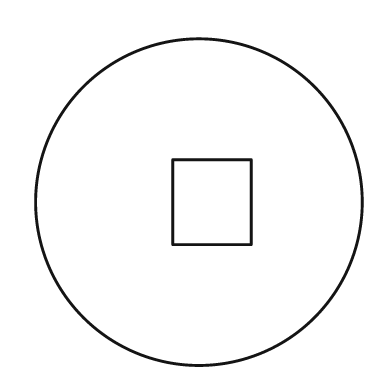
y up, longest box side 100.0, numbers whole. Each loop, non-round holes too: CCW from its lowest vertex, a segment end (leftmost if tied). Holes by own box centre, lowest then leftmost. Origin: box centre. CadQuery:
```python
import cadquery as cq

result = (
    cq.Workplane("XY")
    .moveTo(0.0, 0.0)
    .circle(50.0)
    .moveTo(-8.0, -13.0)
    .lineTo(16.0, -13.0)
    .lineTo(16.0, 13.0)
    .lineTo(-8.0, 13.0)
    .close()
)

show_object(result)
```